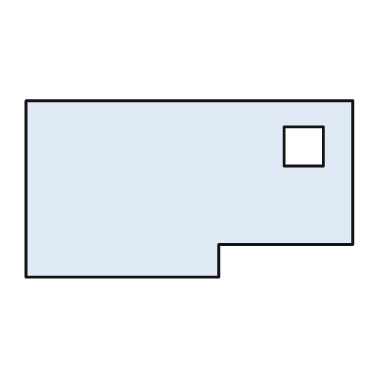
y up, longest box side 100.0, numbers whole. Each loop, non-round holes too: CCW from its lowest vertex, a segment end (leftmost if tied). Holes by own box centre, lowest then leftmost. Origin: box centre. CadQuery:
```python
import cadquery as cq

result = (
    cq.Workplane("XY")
    .moveTo(-50.0, -27.0)
    .lineTo(9.0, -27.0)
    .lineTo(9.0, -17.0)
    .lineTo(50.0, -17.0)
    .lineTo(50.0, 27.0)
    .lineTo(-50.0, 27.0)
    .close()
    .moveTo(29.0, 7.0)
    .lineTo(41.0, 7.0)
    .lineTo(41.0, 19.0)
    .lineTo(29.0, 19.0)
    .close()
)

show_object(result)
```